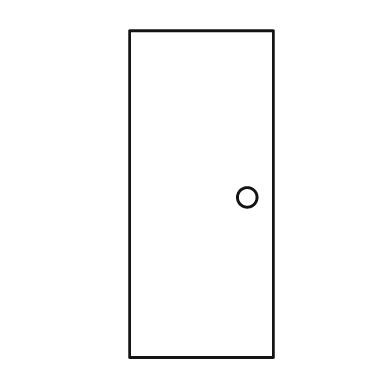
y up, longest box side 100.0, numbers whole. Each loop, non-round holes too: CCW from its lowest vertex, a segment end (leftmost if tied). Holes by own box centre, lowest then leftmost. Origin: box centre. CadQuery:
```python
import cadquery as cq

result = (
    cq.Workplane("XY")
    .moveTo(-22.0, -50.0)
    .lineTo(22.0, -50.0)
    .lineTo(22.0, 50.0)
    .lineTo(-22.0, 50.0)
    .close()
    .moveTo(14.0, -1.0)
    .circle(3.0)
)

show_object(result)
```